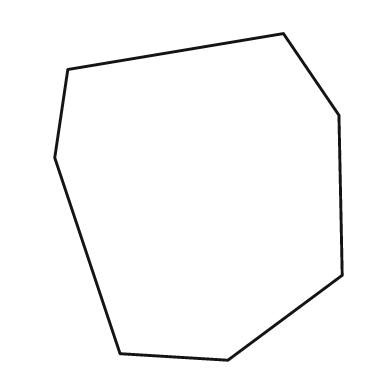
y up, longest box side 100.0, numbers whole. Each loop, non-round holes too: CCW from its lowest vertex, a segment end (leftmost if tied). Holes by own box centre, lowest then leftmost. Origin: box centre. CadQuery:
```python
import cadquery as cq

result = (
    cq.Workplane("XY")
    .moveTo(9.0, -50.0)
    .lineTo(44.0, -24.0)
    .lineTo(43.0, 25.0)
    .lineTo(26.0, 50.0)
    .lineTo(-40.0, 39.0)
    .lineTo(-44.0, 12.0)
    .lineTo(-24.0, -48.0)
    .close()
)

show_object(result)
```